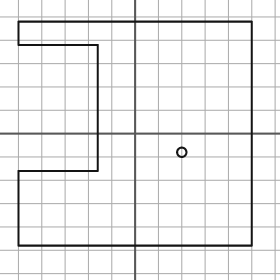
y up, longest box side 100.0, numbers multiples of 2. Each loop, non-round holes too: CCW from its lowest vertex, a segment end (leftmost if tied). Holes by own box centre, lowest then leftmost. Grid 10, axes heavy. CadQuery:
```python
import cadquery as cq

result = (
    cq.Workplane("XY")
    .moveTo(-50.0, -48.0)
    .lineTo(50.0, -48.0)
    .lineTo(50.0, 48.0)
    .lineTo(-50.0, 48.0)
    .lineTo(-50.0, 38.0)
    .lineTo(-16.0, 38.0)
    .lineTo(-16.0, -16.0)
    .lineTo(-50.0, -16.0)
    .close()
    .moveTo(20.0, -8.0)
    .circle(2.0)
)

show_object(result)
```